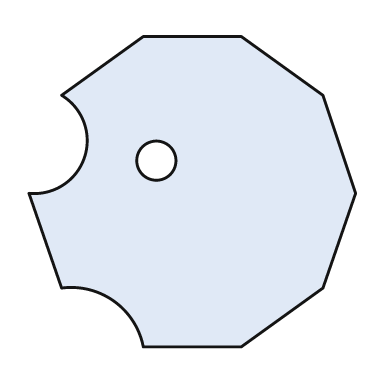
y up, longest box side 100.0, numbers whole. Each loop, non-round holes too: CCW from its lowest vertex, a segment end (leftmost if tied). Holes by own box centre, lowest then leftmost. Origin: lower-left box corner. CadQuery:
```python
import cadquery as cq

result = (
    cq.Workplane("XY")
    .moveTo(35.0, 0.0)
    .lineTo(65.0, 0.0)
    .lineTo(90.0, 18.0)
    .lineTo(100.0, 47.0)
    .lineTo(90.0, 77.0)
    .lineTo(65.0, 95.0)
    .lineTo(35.0, 95.0)
    .lineTo(10.0, 77.0)
    .threePointArc((17.0, 58.0), (0.0, 47.0))
    .lineTo(10.0, 18.0)
    .threePointArc((26.0, 14.0), (35.0, 0.0))
    .close()
    .moveTo(39.0, 57.0)
    .circle(6.0)
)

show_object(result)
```